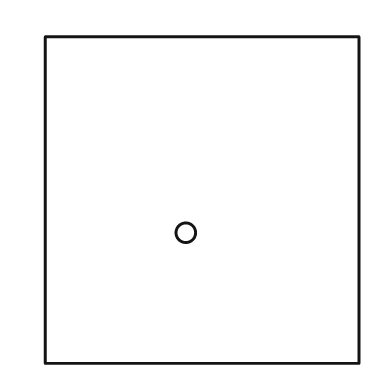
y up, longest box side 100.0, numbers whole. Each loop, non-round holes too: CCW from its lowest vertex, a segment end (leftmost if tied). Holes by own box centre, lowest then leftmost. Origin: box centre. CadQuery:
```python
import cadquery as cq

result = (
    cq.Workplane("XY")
    .moveTo(-48.0, -50.0)
    .lineTo(48.0, -50.0)
    .lineTo(48.0, 50.0)
    .lineTo(-48.0, 50.0)
    .close()
    .moveTo(-5.0, -10.0)
    .circle(3.0)
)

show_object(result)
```